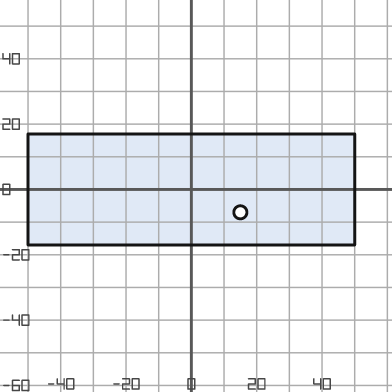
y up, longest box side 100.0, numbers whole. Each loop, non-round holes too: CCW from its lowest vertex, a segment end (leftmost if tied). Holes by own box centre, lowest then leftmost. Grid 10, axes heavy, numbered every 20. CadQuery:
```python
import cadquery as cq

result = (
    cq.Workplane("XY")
    .moveTo(-50.0, -17.0)
    .lineTo(50.0, -17.0)
    .lineTo(50.0, 17.0)
    .lineTo(-50.0, 17.0)
    .close()
    .moveTo(15.0, -7.0)
    .circle(2.0)
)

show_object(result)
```